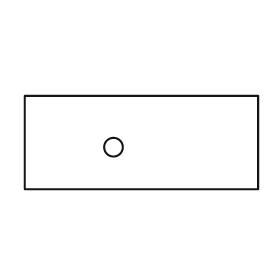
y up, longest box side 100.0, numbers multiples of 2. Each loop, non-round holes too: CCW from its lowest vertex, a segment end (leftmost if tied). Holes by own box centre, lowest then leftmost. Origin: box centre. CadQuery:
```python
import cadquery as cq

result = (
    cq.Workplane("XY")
    .moveTo(-50.0, -20.0)
    .lineTo(50.0, -20.0)
    .lineTo(50.0, 20.0)
    .lineTo(-50.0, 20.0)
    .close()
    .moveTo(-12.0, -2.0)
    .circle(4.0)
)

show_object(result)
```